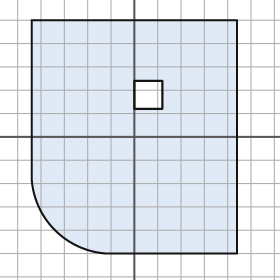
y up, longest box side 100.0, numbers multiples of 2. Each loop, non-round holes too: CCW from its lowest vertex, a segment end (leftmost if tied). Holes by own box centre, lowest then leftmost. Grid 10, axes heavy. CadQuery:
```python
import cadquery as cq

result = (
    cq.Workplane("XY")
    .moveTo(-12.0, -50.0)
    .lineTo(44.0, -50.0)
    .lineTo(44.0, 50.0)
    .lineTo(-44.0, 50.0)
    .lineTo(-44.0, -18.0)
    .threePointArc((-34.0, -40.0), (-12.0, -50.0))
    .close()
    .moveTo(0.0, 12.0)
    .lineTo(12.0, 12.0)
    .lineTo(12.0, 24.0)
    .lineTo(0.0, 24.0)
    .close()
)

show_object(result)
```